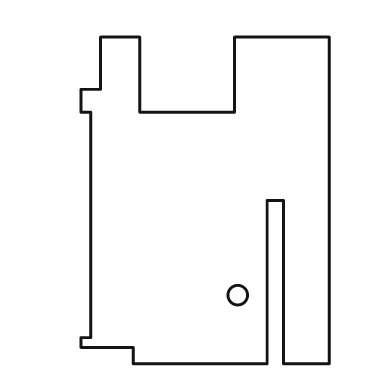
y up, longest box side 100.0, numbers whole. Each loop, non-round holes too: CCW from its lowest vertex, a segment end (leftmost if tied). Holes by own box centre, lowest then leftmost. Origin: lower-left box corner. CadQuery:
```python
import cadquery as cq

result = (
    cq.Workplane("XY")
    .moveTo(16.0, 0.0)
    .lineTo(57.0, 0.0)
    .lineTo(57.0, 50.0)
    .lineTo(62.0, 50.0)
    .lineTo(62.0, 0.0)
    .lineTo(76.0, 0.0)
    .lineTo(76.0, 100.0)
    .lineTo(47.0, 100.0)
    .lineTo(47.0, 77.0)
    .lineTo(18.0, 77.0)
    .lineTo(18.0, 100.0)
    .lineTo(6.0, 100.0)
    .lineTo(6.0, 84.0)
    .lineTo(0.0, 84.0)
    .lineTo(0.0, 77.0)
    .lineTo(3.0, 77.0)
    .lineTo(3.0, 8.0)
    .lineTo(0.0, 8.0)
    .lineTo(0.0, 5.0)
    .lineTo(16.0, 5.0)
    .close()
    .moveTo(48.0, 21.0)
    .circle(3.0)
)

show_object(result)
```